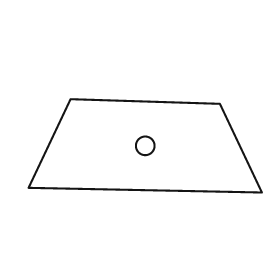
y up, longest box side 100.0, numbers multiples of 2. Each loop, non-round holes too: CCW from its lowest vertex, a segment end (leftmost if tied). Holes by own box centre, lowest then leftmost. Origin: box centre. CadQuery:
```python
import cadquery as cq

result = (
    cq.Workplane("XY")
    .moveTo(50.0, -20.0)
    .lineTo(32.0, 18.0)
    .lineTo(-32.0, 20.0)
    .lineTo(-50.0, -18.0)
    .close()
    .moveTo(0.0, 0.0)
    .circle(4.0)
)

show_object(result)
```